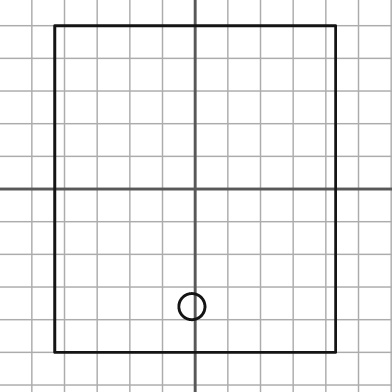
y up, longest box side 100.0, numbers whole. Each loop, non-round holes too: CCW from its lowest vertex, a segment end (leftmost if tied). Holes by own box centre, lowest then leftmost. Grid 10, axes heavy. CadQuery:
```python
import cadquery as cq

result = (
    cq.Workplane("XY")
    .moveTo(-43.0, -50.0)
    .lineTo(43.0, -50.0)
    .lineTo(43.0, 50.0)
    .lineTo(-43.0, 50.0)
    .close()
    .moveTo(-1.0, -36.0)
    .circle(4.0)
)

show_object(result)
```